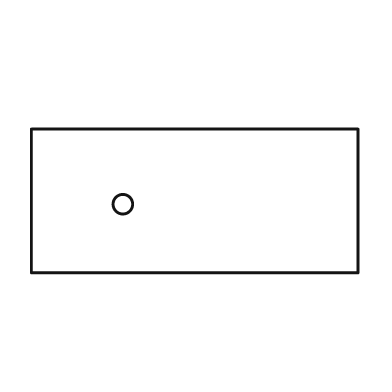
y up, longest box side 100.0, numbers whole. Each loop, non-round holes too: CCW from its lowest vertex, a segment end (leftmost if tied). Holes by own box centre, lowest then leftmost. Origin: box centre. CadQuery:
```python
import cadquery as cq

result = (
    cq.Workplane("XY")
    .moveTo(-50.0, -22.0)
    .lineTo(50.0, -22.0)
    .lineTo(50.0, 22.0)
    .lineTo(-50.0, 22.0)
    .close()
    .moveTo(-22.0, -1.0)
    .circle(3.0)
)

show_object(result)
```